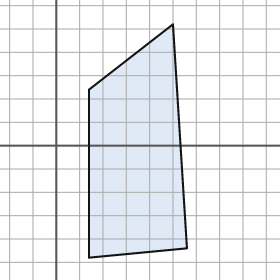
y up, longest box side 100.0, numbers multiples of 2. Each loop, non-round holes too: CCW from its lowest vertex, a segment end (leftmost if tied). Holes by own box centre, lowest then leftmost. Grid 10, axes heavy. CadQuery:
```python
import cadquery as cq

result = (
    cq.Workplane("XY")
    .moveTo(14.0, -48.0)
    .lineTo(56.0, -44.0)
    .lineTo(50.0, 52.0)
    .lineTo(14.0, 24.0)
    .close()
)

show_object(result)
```